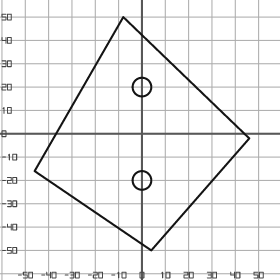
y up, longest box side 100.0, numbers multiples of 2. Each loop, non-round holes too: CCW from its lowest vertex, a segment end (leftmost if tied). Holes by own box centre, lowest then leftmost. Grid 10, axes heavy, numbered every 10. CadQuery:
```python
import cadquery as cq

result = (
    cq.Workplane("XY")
    .moveTo(4.0, -50.0)
    .lineTo(46.0, -2.0)
    .lineTo(-8.0, 50.0)
    .lineTo(-46.0, -16.0)
    .close()
    .moveTo(0.0, -20.0)
    .circle(4.0)
    .moveTo(0.0, 20.0)
    .circle(4.0)
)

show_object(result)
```